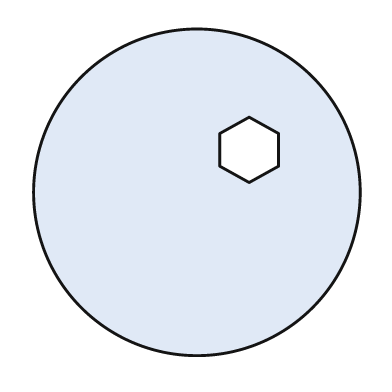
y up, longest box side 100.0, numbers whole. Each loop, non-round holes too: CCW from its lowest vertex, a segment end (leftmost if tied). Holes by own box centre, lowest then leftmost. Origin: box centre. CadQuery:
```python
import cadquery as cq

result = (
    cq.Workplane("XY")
    .moveTo(0.0, 0.0)
    .circle(50.0)
    .moveTo(16.0, 3.0)
    .lineTo(25.0, 8.0)
    .lineTo(25.0, 18.0)
    .lineTo(16.0, 23.0)
    .lineTo(7.0, 18.0)
    .lineTo(7.0, 8.0)
    .close()
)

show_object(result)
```